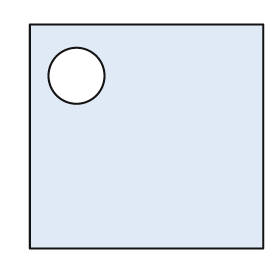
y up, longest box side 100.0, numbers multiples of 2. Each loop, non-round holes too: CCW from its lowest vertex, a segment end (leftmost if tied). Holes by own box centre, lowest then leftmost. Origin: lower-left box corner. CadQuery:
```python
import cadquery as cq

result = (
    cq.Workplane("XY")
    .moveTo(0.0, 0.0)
    .lineTo(100.0, 0.0)
    .lineTo(100.0, 96.0)
    .lineTo(0.0, 96.0)
    .close()
    .moveTo(20.0, 74.0)
    .circle(12.0)
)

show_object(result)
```